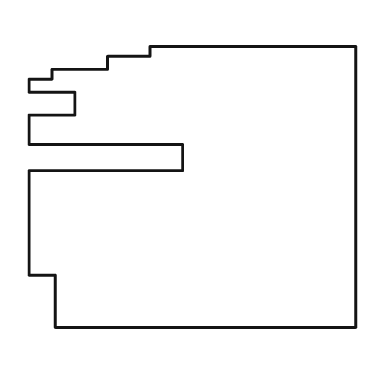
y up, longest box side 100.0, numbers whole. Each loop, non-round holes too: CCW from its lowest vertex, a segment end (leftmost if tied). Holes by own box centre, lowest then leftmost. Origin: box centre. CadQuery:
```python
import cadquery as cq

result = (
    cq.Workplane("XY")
    .moveTo(-42.0, -43.0)
    .lineTo(50.0, -43.0)
    .lineTo(50.0, 43.0)
    .lineTo(-13.0, 43.0)
    .lineTo(-13.0, 40.0)
    .lineTo(-26.0, 40.0)
    .lineTo(-26.0, 36.0)
    .lineTo(-43.0, 36.0)
    .lineTo(-43.0, 33.0)
    .lineTo(-50.0, 33.0)
    .lineTo(-50.0, 29.0)
    .lineTo(-36.0, 29.0)
    .lineTo(-36.0, 22.0)
    .lineTo(-50.0, 22.0)
    .lineTo(-50.0, 13.0)
    .lineTo(-3.0, 13.0)
    .lineTo(-3.0, 5.0)
    .lineTo(-50.0, 5.0)
    .lineTo(-50.0, -27.0)
    .lineTo(-42.0, -27.0)
    .close()
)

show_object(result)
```